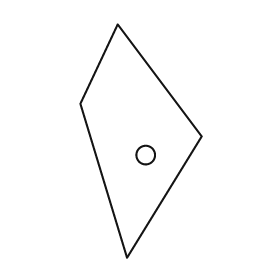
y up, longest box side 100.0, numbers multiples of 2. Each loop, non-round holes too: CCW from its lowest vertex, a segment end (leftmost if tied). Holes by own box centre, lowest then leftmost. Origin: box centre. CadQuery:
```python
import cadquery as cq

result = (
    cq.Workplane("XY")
    .moveTo(-6.0, -50.0)
    .lineTo(26.0, 2.0)
    .lineTo(-10.0, 50.0)
    .lineTo(-26.0, 16.0)
    .close()
    .moveTo(2.0, -6.0)
    .circle(4.0)
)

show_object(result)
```